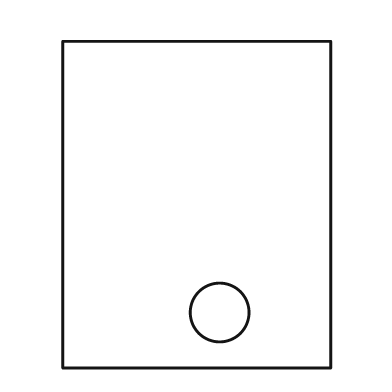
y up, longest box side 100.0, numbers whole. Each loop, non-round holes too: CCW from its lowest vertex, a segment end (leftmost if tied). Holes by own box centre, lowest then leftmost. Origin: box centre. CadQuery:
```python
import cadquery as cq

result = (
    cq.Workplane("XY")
    .moveTo(-41.0, -50.0)
    .lineTo(41.0, -50.0)
    .lineTo(41.0, 50.0)
    .lineTo(-41.0, 50.0)
    .close()
    .moveTo(7.0, -33.0)
    .circle(9.0)
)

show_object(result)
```